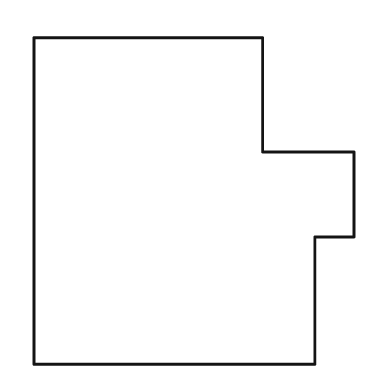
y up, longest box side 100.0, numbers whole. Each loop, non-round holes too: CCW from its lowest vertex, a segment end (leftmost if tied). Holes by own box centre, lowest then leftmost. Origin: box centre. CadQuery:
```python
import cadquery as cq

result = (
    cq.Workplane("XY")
    .moveTo(-49.0, -50.0)
    .lineTo(37.0, -50.0)
    .lineTo(37.0, -11.0)
    .lineTo(49.0, -11.0)
    .lineTo(49.0, 15.0)
    .lineTo(21.0, 15.0)
    .lineTo(21.0, 50.0)
    .lineTo(-49.0, 50.0)
    .close()
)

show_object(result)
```